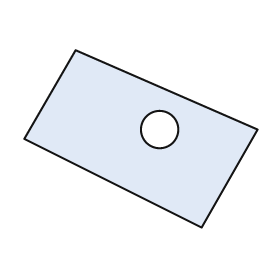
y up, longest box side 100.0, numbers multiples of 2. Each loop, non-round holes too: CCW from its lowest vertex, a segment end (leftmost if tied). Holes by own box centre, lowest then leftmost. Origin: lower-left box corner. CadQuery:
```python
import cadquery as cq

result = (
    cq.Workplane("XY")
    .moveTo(76.0, 0.0)
    .lineTo(100.0, 42.0)
    .lineTo(22.0, 76.0)
    .lineTo(0.0, 38.0)
    .close()
    .moveTo(58.0, 42.0)
    .circle(8.0)
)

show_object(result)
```